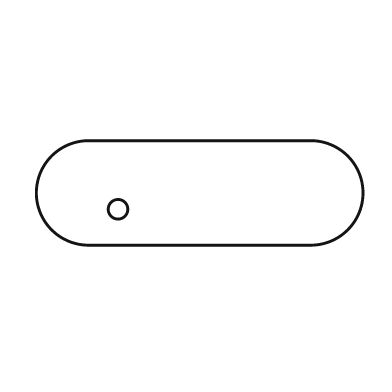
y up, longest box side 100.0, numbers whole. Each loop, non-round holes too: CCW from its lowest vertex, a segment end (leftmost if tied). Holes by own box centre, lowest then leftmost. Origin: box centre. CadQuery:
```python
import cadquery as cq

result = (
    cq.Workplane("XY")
    .moveTo(-34.0, -16.0)
    .lineTo(34.0, -16.0)
    .threePointArc((50.0, 0.0), (34.0, 16.0))
    .lineTo(-34.0, 16.0)
    .threePointArc((-50.0, 0.0), (-34.0, -16.0))
    .close()
    .moveTo(-25.0, -5.0)
    .circle(3.0)
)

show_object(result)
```